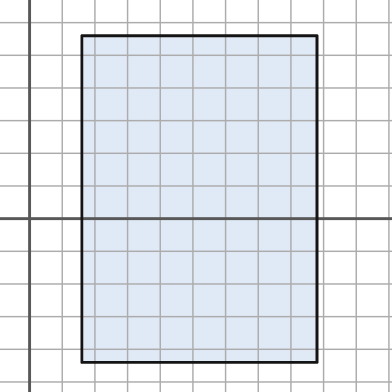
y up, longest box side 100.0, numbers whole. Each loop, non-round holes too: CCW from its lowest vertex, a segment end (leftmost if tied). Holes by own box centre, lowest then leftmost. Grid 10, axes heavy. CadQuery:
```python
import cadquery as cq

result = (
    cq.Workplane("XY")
    .moveTo(16.0, -44.0)
    .lineTo(88.0, -44.0)
    .lineTo(88.0, 56.0)
    .lineTo(16.0, 56.0)
    .close()
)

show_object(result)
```